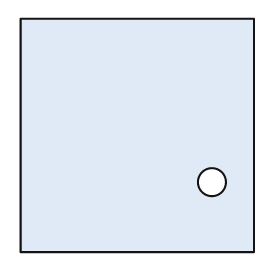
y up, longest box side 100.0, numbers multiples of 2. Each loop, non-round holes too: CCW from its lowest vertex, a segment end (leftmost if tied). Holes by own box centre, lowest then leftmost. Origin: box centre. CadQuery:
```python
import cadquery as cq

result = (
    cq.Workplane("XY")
    .moveTo(-50.0, -50.0)
    .lineTo(50.0, -50.0)
    .lineTo(50.0, 50.0)
    .lineTo(-50.0, 50.0)
    .close()
    .moveTo(32.0, -20.0)
    .circle(6.0)
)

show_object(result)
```